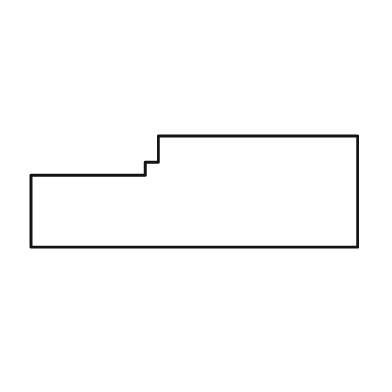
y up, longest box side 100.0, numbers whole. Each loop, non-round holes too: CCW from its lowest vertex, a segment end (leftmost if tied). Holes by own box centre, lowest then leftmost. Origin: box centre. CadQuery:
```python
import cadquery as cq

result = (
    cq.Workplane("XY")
    .moveTo(-50.0, -17.0)
    .lineTo(50.0, -17.0)
    .lineTo(50.0, 17.0)
    .lineTo(-11.0, 17.0)
    .lineTo(-11.0, 9.0)
    .lineTo(-15.0, 9.0)
    .lineTo(-15.0, 5.0)
    .lineTo(-50.0, 5.0)
    .close()
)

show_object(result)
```